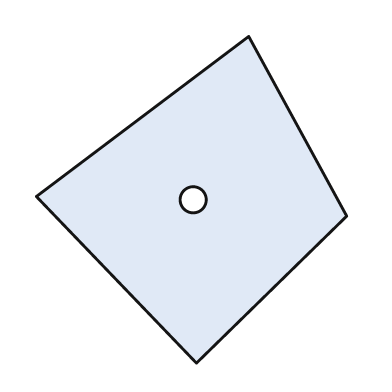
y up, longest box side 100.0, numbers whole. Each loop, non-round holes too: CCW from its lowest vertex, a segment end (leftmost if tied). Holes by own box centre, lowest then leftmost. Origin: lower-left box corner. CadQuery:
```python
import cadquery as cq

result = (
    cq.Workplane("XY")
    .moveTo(49.0, 0.0)
    .lineTo(95.0, 45.0)
    .lineTo(65.0, 100.0)
    .lineTo(0.0, 51.0)
    .close()
    .moveTo(48.0, 50.0)
    .circle(4.0)
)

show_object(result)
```